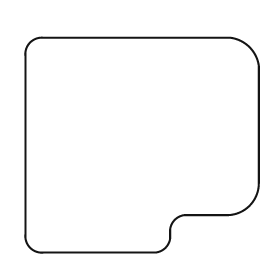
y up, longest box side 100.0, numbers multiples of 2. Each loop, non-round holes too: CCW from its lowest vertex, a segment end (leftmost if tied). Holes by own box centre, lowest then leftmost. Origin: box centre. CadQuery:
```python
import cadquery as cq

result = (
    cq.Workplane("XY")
    .moveTo(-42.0, -46.0)
    .lineTo(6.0, -46.0)
    .threePointArc((10.0, -44.0), (12.0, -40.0))
    .lineTo(12.0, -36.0)
    .threePointArc((14.0, -32.0), (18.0, -30.0))
    .lineTo(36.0, -30.0)
    .threePointArc((46.0, -26.0), (50.0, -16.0))
    .lineTo(50.0, 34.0)
    .threePointArc((46.0, 42.0), (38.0, 46.0))
    .lineTo(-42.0, 46.0)
    .threePointArc((-48.0, 44.0), (-50.0, 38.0))
    .lineTo(-50.0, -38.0)
    .threePointArc((-48.0, -44.0), (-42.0, -46.0))
    .close()
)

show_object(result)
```